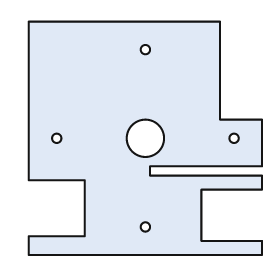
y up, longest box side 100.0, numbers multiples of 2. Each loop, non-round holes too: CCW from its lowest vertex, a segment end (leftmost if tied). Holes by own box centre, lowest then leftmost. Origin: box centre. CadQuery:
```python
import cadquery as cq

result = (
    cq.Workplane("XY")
    .moveTo(-50.0, -50.0)
    .lineTo(50.0, -50.0)
    .lineTo(50.0, -44.0)
    .lineTo(24.0, -44.0)
    .lineTo(24.0, -22.0)
    .lineTo(50.0, -22.0)
    .lineTo(50.0, -16.0)
    .lineTo(2.0, -16.0)
    .lineTo(2.0, -12.0)
    .lineTo(50.0, -12.0)
    .lineTo(50.0, 8.0)
    .lineTo(32.0, 8.0)
    .lineTo(32.0, 50.0)
    .lineTo(-50.0, 50.0)
    .lineTo(-50.0, -18.0)
    .lineTo(-26.0, -18.0)
    .lineTo(-26.0, -42.0)
    .lineTo(-50.0, -42.0)
    .close()
    .moveTo(0.0, -38.0)
    .circle(2.0)
    .moveTo(-38.0, 0.0)
    .circle(2.0)
    .moveTo(0.0, 0.0)
    .circle(8.0)
    .moveTo(38.0, 0.0)
    .circle(2.0)
    .moveTo(0.0, 38.0)
    .circle(2.0)
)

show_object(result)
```